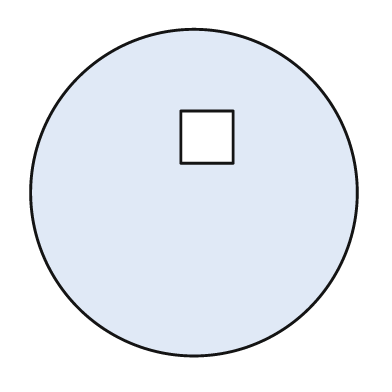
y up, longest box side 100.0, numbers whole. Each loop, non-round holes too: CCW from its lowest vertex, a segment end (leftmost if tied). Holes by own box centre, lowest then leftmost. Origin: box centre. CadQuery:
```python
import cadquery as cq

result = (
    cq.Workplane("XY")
    .moveTo(0.0, 0.0)
    .circle(50.0)
    .moveTo(-4.0, 9.0)
    .lineTo(12.0, 9.0)
    .lineTo(12.0, 25.0)
    .lineTo(-4.0, 25.0)
    .close()
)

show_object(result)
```